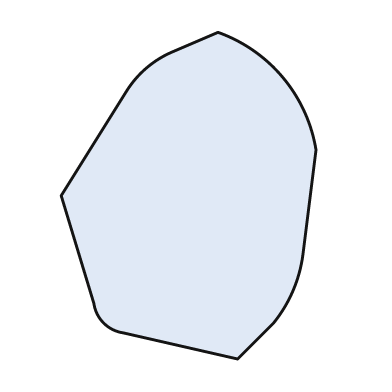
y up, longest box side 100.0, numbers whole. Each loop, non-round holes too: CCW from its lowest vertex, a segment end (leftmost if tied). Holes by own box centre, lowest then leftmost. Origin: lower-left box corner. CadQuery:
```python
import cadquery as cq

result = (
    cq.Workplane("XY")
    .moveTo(54.0, 0.0)
    .lineTo(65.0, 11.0)
    .threePointArc((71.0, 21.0), (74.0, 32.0))
    .lineTo(78.0, 64.0)
    .threePointArc((68.0, 86.0), (48.0, 100.0))
    .lineTo(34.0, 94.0)
    .threePointArc((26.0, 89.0), (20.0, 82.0))
    .lineTo(0.0, 50.0)
    .lineTo(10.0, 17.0)
    .threePointArc((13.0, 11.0), (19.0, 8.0))
    .close()
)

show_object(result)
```